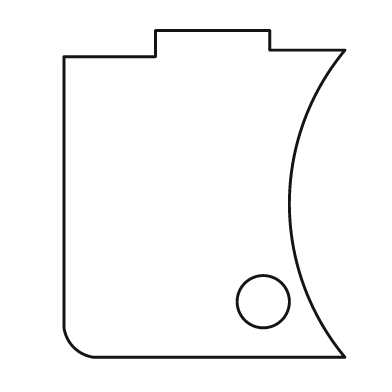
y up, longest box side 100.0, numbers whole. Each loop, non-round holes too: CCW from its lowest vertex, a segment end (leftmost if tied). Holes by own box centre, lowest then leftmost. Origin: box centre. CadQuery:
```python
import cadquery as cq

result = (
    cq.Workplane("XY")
    .moveTo(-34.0, -50.0)
    .lineTo(43.0, -50.0)
    .threePointArc((26.0, -3.0), (43.0, 44.0))
    .lineTo(20.0, 44.0)
    .lineTo(20.0, 50.0)
    .lineTo(-15.0, 50.0)
    .lineTo(-15.0, 42.0)
    .lineTo(-43.0, 42.0)
    .lineTo(-43.0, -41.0)
    .threePointArc((-40.0, -47.0), (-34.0, -50.0))
    .close()
    .moveTo(18.0, -33.0)
    .circle(8.0)
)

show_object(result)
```